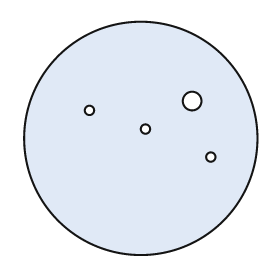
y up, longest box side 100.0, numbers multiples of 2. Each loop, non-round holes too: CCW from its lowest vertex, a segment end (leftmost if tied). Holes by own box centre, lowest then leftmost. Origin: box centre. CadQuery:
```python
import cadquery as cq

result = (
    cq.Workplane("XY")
    .moveTo(0.0, 0.0)
    .circle(50.0)
    .moveTo(30.0, -8.0)
    .circle(2.0)
    .moveTo(2.0, 4.0)
    .circle(2.0)
    .moveTo(-22.0, 12.0)
    .circle(2.0)
    .moveTo(22.0, 16.0)
    .circle(4.0)
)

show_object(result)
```